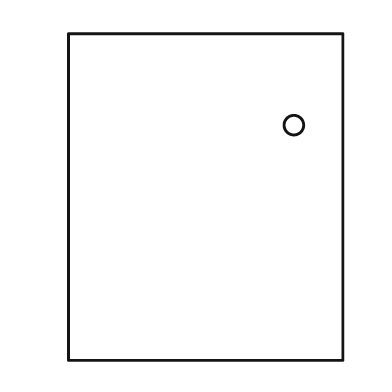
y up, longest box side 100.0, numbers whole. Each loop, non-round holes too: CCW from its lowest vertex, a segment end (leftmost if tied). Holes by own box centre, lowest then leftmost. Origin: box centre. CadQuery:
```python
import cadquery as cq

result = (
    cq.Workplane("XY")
    .moveTo(-42.0, -50.0)
    .lineTo(42.0, -50.0)
    .lineTo(42.0, 50.0)
    .lineTo(-42.0, 50.0)
    .close()
    .moveTo(27.0, 22.0)
    .circle(3.0)
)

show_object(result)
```